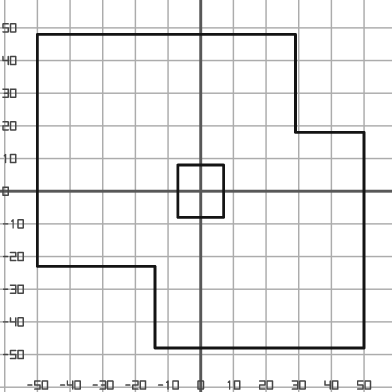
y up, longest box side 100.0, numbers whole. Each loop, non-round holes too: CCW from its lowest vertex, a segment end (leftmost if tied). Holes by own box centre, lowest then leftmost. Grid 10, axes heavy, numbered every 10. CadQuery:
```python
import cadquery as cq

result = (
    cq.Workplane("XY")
    .moveTo(-14.0, -48.0)
    .lineTo(50.0, -48.0)
    .lineTo(50.0, 18.0)
    .lineTo(29.0, 18.0)
    .lineTo(29.0, 48.0)
    .lineTo(-50.0, 48.0)
    .lineTo(-50.0, -23.0)
    .lineTo(-14.0, -23.0)
    .close()
    .moveTo(-7.0, -8.0)
    .lineTo(7.0, -8.0)
    .lineTo(7.0, 8.0)
    .lineTo(-7.0, 8.0)
    .close()
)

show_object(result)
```